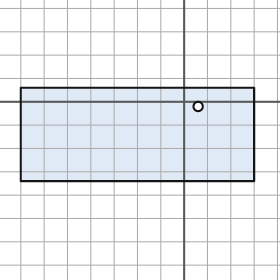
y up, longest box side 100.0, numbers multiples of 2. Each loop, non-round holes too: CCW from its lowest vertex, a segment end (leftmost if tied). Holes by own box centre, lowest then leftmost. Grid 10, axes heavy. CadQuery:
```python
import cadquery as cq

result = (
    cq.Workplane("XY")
    .moveTo(-70.0, -34.0)
    .lineTo(30.0, -34.0)
    .lineTo(30.0, 6.0)
    .lineTo(-70.0, 6.0)
    .close()
    .moveTo(6.0, -2.0)
    .circle(2.0)
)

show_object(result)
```